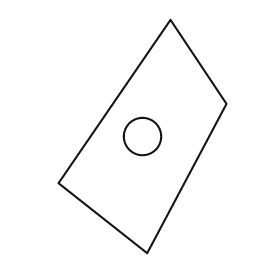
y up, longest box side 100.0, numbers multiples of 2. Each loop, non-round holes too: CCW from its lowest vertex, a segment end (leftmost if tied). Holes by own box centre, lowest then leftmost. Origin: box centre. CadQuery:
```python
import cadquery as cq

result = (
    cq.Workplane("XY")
    .moveTo(2.0, -50.0)
    .lineTo(36.0, 14.0)
    .lineTo(12.0, 50.0)
    .lineTo(-36.0, -20.0)
    .close()
    .moveTo(0.0, 0.0)
    .circle(8.0)
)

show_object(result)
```